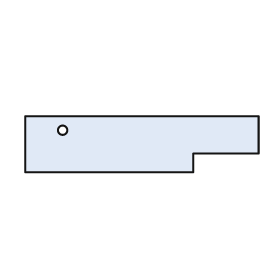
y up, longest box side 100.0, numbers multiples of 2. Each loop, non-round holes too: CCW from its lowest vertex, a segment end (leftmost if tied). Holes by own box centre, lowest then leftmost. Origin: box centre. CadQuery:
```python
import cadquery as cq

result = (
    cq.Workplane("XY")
    .moveTo(-50.0, -12.0)
    .lineTo(22.0, -12.0)
    .lineTo(22.0, -4.0)
    .lineTo(50.0, -4.0)
    .lineTo(50.0, 12.0)
    .lineTo(-50.0, 12.0)
    .close()
    .moveTo(-34.0, 6.0)
    .circle(2.0)
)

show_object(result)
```